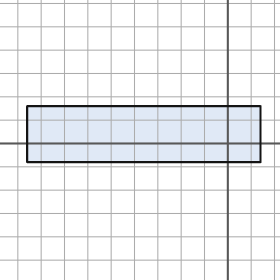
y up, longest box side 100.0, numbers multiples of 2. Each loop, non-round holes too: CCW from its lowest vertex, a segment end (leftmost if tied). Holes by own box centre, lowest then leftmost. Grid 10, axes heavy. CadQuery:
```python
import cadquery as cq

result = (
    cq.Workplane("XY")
    .moveTo(-86.0, -8.0)
    .lineTo(14.0, -8.0)
    .lineTo(14.0, 16.0)
    .lineTo(-86.0, 16.0)
    .close()
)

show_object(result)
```